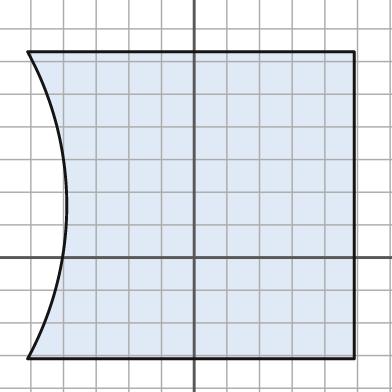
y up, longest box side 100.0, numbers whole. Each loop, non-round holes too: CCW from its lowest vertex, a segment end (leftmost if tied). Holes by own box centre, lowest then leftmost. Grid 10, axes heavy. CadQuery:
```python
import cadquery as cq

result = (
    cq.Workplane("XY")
    .moveTo(-51.0, -31.0)
    .lineTo(49.0, -31.0)
    .lineTo(49.0, 63.0)
    .lineTo(-51.0, 63.0)
    .threePointArc((-39.0, 16.0), (-51.0, -31.0))
    .close()
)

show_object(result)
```